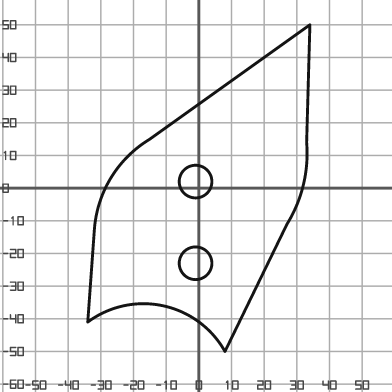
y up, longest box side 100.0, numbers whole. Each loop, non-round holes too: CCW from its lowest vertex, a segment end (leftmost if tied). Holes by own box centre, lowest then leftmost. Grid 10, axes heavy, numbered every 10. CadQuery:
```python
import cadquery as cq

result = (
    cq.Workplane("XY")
    .moveTo(8.0, -50.0)
    .lineTo(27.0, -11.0)
    .threePointArc((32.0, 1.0), (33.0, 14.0))
    .lineTo(34.0, 50.0)
    .lineTo(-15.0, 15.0)
    .threePointArc((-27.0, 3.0), (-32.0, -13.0))
    .lineTo(-34.0, -41.0)
    .threePointArc((-11.0, -36.0), (8.0, -50.0))
    .close()
    .moveTo(-1.0, -23.0)
    .circle(5.0)
    .moveTo(-1.0, 2.0)
    .circle(5.0)
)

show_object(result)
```